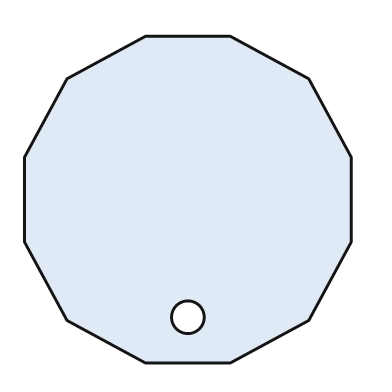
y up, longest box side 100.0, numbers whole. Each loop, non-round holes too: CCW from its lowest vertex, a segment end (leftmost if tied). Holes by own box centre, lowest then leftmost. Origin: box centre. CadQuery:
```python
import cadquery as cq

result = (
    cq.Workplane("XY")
    .moveTo(-13.0, -50.0)
    .lineTo(13.0, -50.0)
    .lineTo(37.0, -37.0)
    .lineTo(50.0, -13.0)
    .lineTo(50.0, 13.0)
    .lineTo(37.0, 37.0)
    .lineTo(13.0, 50.0)
    .lineTo(-13.0, 50.0)
    .lineTo(-37.0, 37.0)
    .lineTo(-50.0, 13.0)
    .lineTo(-50.0, -13.0)
    .lineTo(-37.0, -37.0)
    .close()
    .moveTo(0.0, -36.0)
    .circle(5.0)
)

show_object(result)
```